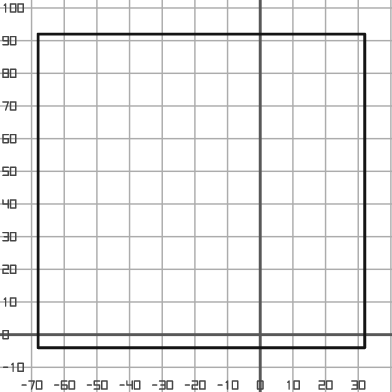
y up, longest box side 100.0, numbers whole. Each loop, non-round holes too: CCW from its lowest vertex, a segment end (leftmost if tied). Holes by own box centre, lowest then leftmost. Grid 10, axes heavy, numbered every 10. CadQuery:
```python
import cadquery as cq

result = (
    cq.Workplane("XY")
    .moveTo(-68.0, -4.0)
    .lineTo(32.0, -4.0)
    .lineTo(32.0, 92.0)
    .lineTo(-68.0, 92.0)
    .close()
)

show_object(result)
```